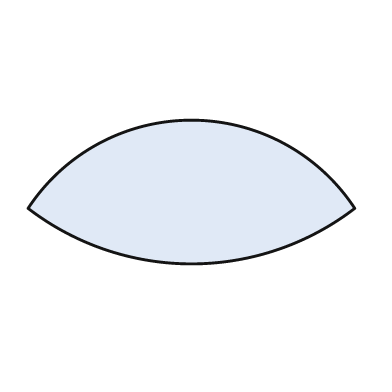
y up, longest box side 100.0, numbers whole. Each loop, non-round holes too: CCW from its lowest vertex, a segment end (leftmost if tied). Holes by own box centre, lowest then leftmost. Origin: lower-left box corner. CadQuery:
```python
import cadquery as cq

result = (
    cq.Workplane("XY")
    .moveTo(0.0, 17.0)
    .threePointArc((50.0, 0.0), (100.0, 17.0))
    .threePointArc((50.0, 44.0), (0.0, 17.0))
    .close()
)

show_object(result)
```